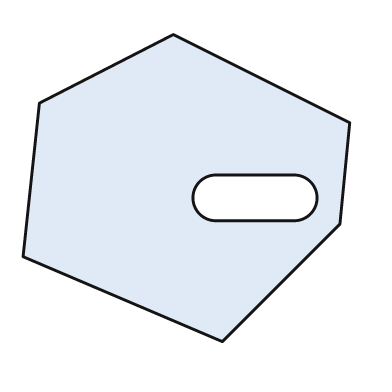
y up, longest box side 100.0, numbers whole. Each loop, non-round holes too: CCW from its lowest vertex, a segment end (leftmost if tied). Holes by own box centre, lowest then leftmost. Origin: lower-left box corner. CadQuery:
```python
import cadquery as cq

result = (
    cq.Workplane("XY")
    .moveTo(61.0, 0.0)
    .lineTo(97.0, 36.0)
    .lineTo(100.0, 67.0)
    .lineTo(46.0, 94.0)
    .lineTo(5.0, 73.0)
    .lineTo(0.0, 26.0)
    .close()
    .moveTo(59.0, 37.0)
    .lineTo(83.0, 37.0)
    .threePointArc((90.0, 44.0), (83.0, 51.0))
    .lineTo(59.0, 51.0)
    .threePointArc((52.0, 44.0), (59.0, 37.0))
    .close()
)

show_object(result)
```